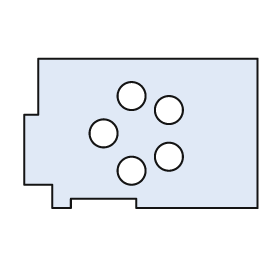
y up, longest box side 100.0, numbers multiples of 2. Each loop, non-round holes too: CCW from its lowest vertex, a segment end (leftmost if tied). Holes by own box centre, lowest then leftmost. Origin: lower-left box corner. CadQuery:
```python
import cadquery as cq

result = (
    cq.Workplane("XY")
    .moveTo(12.0, 0.0)
    .lineTo(20.0, 0.0)
    .lineTo(20.0, 4.0)
    .lineTo(48.0, 4.0)
    .lineTo(48.0, 0.0)
    .lineTo(100.0, 0.0)
    .lineTo(100.0, 64.0)
    .lineTo(6.0, 64.0)
    .lineTo(6.0, 40.0)
    .lineTo(0.0, 40.0)
    .lineTo(0.0, 10.0)
    .lineTo(12.0, 10.0)
    .close()
    .moveTo(46.0, 16.0)
    .circle(6.0)
    .moveTo(62.0, 22.0)
    .circle(6.0)
    .moveTo(34.0, 32.0)
    .circle(6.0)
    .moveTo(62.0, 42.0)
    .circle(6.0)
    .moveTo(46.0, 48.0)
    .circle(6.0)
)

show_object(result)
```